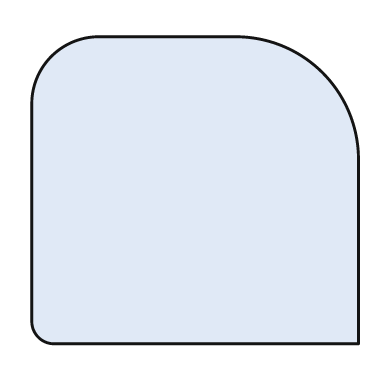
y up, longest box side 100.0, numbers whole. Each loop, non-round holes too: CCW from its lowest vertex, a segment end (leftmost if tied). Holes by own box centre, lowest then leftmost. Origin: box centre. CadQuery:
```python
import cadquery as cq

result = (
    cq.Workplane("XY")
    .moveTo(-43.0, -47.0)
    .lineTo(50.0, -47.0)
    .lineTo(50.0, 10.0)
    .threePointArc((39.0, 36.0), (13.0, 47.0))
    .lineTo(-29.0, 47.0)
    .threePointArc((-44.0, 41.0), (-50.0, 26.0))
    .lineTo(-50.0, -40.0)
    .threePointArc((-48.0, -45.0), (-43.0, -47.0))
    .close()
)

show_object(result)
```